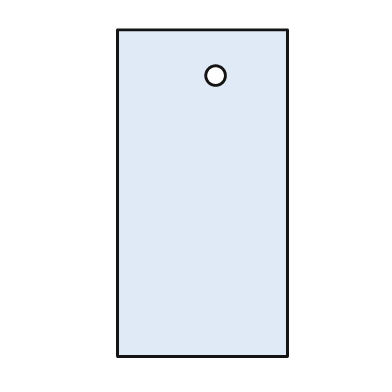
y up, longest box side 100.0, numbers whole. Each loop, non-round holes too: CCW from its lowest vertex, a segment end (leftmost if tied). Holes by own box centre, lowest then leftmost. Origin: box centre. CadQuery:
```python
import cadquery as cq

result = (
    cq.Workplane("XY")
    .moveTo(-26.0, -50.0)
    .lineTo(26.0, -50.0)
    .lineTo(26.0, 50.0)
    .lineTo(-26.0, 50.0)
    .close()
    .moveTo(4.0, 36.0)
    .circle(3.0)
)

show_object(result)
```